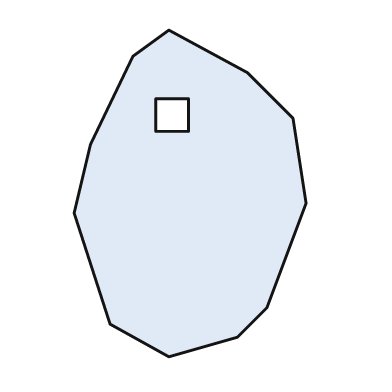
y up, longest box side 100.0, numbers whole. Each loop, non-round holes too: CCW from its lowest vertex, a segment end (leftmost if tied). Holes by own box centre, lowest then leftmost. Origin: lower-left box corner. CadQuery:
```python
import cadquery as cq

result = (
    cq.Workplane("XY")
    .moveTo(29.0, 0.0)
    .lineTo(50.0, 6.0)
    .lineTo(59.0, 15.0)
    .lineTo(71.0, 47.0)
    .lineTo(67.0, 73.0)
    .lineTo(53.0, 87.0)
    .lineTo(29.0, 100.0)
    .lineTo(18.0, 92.0)
    .lineTo(5.0, 65.0)
    .lineTo(0.0, 44.0)
    .lineTo(11.0, 10.0)
    .close()
    .moveTo(25.0, 69.0)
    .lineTo(35.0, 69.0)
    .lineTo(35.0, 79.0)
    .lineTo(25.0, 79.0)
    .close()
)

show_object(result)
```